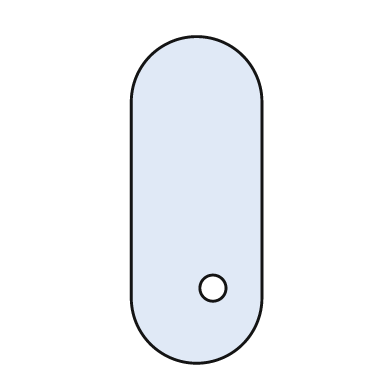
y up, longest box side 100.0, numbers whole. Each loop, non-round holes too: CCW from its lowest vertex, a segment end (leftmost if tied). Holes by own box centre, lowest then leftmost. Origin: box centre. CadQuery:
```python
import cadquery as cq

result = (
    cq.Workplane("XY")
    .moveTo(-20.0, -30.0)
    .threePointArc((0.0, -50.0), (20.0, -30.0))
    .lineTo(20.0, 30.0)
    .threePointArc((0.0, 50.0), (-20.0, 30.0))
    .close()
    .moveTo(5.0, -27.0)
    .circle(4.0)
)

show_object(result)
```